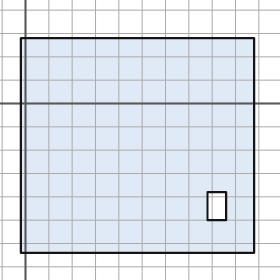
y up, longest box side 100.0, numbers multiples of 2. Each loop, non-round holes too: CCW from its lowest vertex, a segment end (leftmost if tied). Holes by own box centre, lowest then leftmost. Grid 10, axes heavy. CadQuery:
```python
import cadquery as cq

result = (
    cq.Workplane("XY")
    .moveTo(-2.0, -64.0)
    .lineTo(98.0, -64.0)
    .lineTo(98.0, 28.0)
    .lineTo(-2.0, 28.0)
    .close()
    .moveTo(78.0, -50.0)
    .lineTo(86.0, -50.0)
    .lineTo(86.0, -38.0)
    .lineTo(78.0, -38.0)
    .close()
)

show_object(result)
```